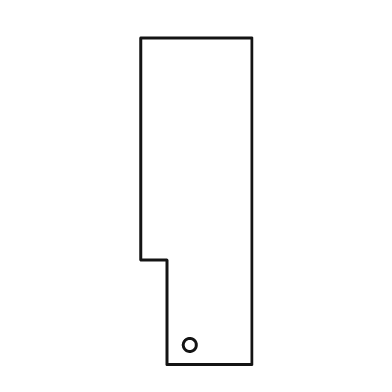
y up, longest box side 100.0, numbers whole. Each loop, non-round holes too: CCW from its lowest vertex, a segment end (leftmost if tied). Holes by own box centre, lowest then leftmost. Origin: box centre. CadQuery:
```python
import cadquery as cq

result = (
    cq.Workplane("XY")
    .moveTo(-9.0, -50.0)
    .lineTo(17.0, -50.0)
    .lineTo(17.0, 50.0)
    .lineTo(-17.0, 50.0)
    .lineTo(-17.0, -18.0)
    .lineTo(-9.0, -18.0)
    .close()
    .moveTo(-2.0, -44.0)
    .circle(2.0)
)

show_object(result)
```